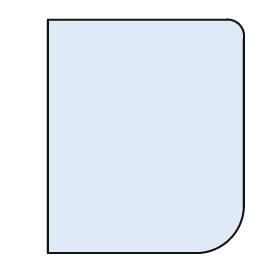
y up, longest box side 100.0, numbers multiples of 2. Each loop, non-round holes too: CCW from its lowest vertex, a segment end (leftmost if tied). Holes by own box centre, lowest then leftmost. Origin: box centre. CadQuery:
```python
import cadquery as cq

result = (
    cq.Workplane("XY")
    .moveTo(-42.0, -50.0)
    .lineTo(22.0, -50.0)
    .threePointArc((36.0, -44.0), (42.0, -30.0))
    .lineTo(42.0, 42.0)
    .threePointArc((40.0, 48.0), (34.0, 50.0))
    .lineTo(-42.0, 50.0)
    .close()
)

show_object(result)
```